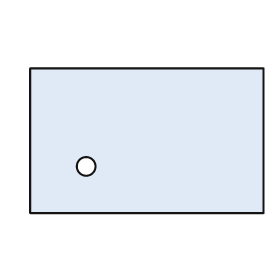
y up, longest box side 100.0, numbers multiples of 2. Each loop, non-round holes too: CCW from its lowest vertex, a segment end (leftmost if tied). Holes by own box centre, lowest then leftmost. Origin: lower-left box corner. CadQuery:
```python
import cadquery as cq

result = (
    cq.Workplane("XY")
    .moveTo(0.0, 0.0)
    .lineTo(100.0, 0.0)
    .lineTo(100.0, 62.0)
    .lineTo(0.0, 62.0)
    .close()
    .moveTo(24.0, 20.0)
    .circle(4.0)
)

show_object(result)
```